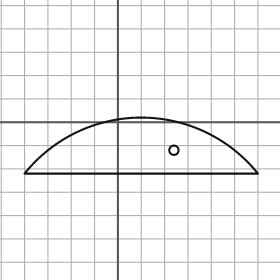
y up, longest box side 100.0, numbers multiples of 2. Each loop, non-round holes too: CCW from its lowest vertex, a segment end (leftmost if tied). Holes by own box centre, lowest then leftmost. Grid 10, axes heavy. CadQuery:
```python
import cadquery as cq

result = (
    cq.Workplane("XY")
    .moveTo(-40.0, -22.0)
    .lineTo(60.0, -22.0)
    .threePointArc((10.0, 2.0), (-40.0, -22.0))
    .close()
    .moveTo(24.0, -12.0)
    .circle(2.0)
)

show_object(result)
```